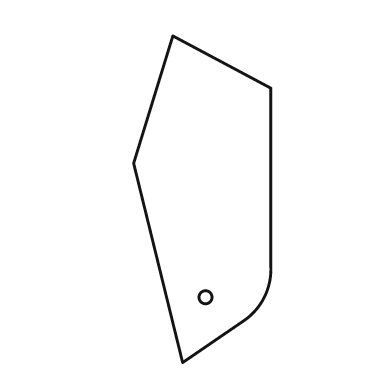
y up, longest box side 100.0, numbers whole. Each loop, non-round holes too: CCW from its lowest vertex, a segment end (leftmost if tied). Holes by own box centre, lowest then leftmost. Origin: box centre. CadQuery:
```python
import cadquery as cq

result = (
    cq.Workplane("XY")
    .moveTo(-6.0, -50.0)
    .lineTo(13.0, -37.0)
    .threePointArc((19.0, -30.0), (21.0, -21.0))
    .lineTo(21.0, 34.0)
    .lineTo(-9.0, 50.0)
    .lineTo(-21.0, 11.0)
    .close()
    .moveTo(1.0, -30.0)
    .circle(2.0)
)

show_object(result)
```